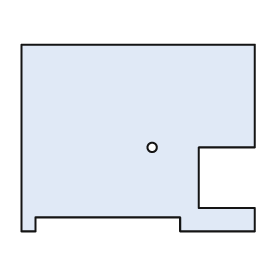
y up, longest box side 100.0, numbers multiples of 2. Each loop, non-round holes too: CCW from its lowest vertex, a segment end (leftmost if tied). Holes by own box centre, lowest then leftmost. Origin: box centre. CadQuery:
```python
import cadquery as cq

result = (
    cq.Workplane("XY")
    .moveTo(-50.0, -40.0)
    .lineTo(-44.0, -40.0)
    .lineTo(-44.0, -34.0)
    .lineTo(18.0, -34.0)
    .lineTo(18.0, -40.0)
    .lineTo(50.0, -40.0)
    .lineTo(50.0, -30.0)
    .lineTo(26.0, -30.0)
    .lineTo(26.0, -4.0)
    .lineTo(50.0, -4.0)
    .lineTo(50.0, 40.0)
    .lineTo(-50.0, 40.0)
    .close()
    .moveTo(6.0, -4.0)
    .circle(2.0)
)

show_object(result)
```